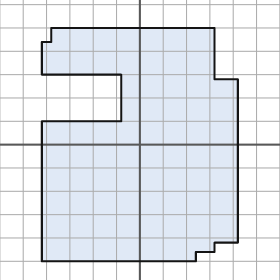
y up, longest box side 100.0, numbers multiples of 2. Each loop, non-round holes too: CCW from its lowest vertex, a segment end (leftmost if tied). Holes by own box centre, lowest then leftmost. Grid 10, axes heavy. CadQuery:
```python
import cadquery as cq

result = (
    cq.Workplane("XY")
    .moveTo(-42.0, -50.0)
    .lineTo(24.0, -50.0)
    .lineTo(24.0, -46.0)
    .lineTo(32.0, -46.0)
    .lineTo(32.0, -42.0)
    .lineTo(42.0, -42.0)
    .lineTo(42.0, 28.0)
    .lineTo(32.0, 28.0)
    .lineTo(32.0, 50.0)
    .lineTo(-38.0, 50.0)
    .lineTo(-38.0, 44.0)
    .lineTo(-42.0, 44.0)
    .lineTo(-42.0, 30.0)
    .lineTo(-8.0, 30.0)
    .lineTo(-8.0, 10.0)
    .lineTo(-42.0, 10.0)
    .close()
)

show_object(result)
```